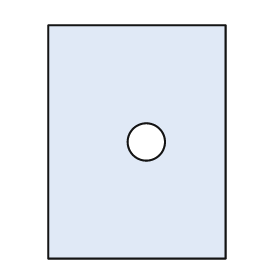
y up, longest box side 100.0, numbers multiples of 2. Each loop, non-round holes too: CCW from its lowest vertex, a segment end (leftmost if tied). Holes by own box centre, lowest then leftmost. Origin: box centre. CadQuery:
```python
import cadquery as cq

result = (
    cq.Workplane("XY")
    .moveTo(-38.0, -50.0)
    .lineTo(38.0, -50.0)
    .lineTo(38.0, 50.0)
    .lineTo(-38.0, 50.0)
    .close()
    .moveTo(4.0, 0.0)
    .circle(8.0)
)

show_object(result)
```